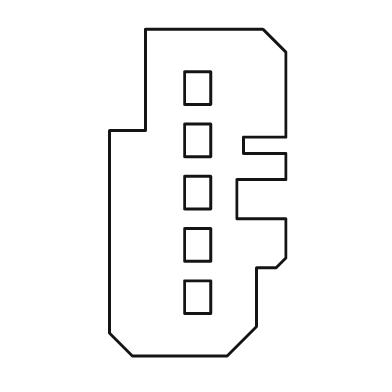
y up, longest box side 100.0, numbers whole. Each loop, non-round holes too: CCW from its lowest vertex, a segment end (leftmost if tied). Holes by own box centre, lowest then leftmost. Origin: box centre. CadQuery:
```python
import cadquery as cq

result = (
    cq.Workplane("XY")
    .moveTo(-20.0, -50.0)
    .lineTo(9.0, -50.0)
    .lineTo(18.0, -41.0)
    .lineTo(18.0, -23.0)
    .lineTo(24.0, -23.0)
    .lineTo(27.0, -20.0)
    .lineTo(27.0, -8.0)
    .lineTo(12.0, -8.0)
    .lineTo(12.0, 4.0)
    .lineTo(27.0, 4.0)
    .lineTo(27.0, 12.0)
    .lineTo(14.0, 12.0)
    .lineTo(14.0, 17.0)
    .lineTo(27.0, 17.0)
    .lineTo(27.0, 43.0)
    .lineTo(20.0, 50.0)
    .lineTo(-16.0, 50.0)
    .lineTo(-16.0, 19.0)
    .lineTo(-27.0, 19.0)
    .lineTo(-27.0, -43.0)
    .close()
    .moveTo(-4.0, -37.0)
    .lineTo(4.0, -37.0)
    .lineTo(4.0, -27.0)
    .lineTo(-4.0, -27.0)
    .close()
    .moveTo(-4.0, -21.0)
    .lineTo(4.0, -21.0)
    .lineTo(4.0, -11.0)
    .lineTo(-4.0, -11.0)
    .close()
    .moveTo(-4.0, -5.0)
    .lineTo(4.0, -5.0)
    .lineTo(4.0, 5.0)
    .lineTo(-4.0, 5.0)
    .close()
    .moveTo(-4.0, 11.0)
    .lineTo(4.0, 11.0)
    .lineTo(4.0, 21.0)
    .lineTo(-4.0, 21.0)
    .close()
    .moveTo(-4.0, 27.0)
    .lineTo(4.0, 27.0)
    .lineTo(4.0, 37.0)
    .lineTo(-4.0, 37.0)
    .close()
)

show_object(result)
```